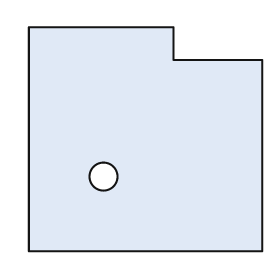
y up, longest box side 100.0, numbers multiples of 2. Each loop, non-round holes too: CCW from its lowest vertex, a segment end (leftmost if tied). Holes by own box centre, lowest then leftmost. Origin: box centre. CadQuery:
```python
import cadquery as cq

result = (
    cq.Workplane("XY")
    .moveTo(-50.0, -48.0)
    .lineTo(50.0, -48.0)
    .lineTo(50.0, 34.0)
    .lineTo(12.0, 34.0)
    .lineTo(12.0, 48.0)
    .lineTo(-50.0, 48.0)
    .close()
    .moveTo(-18.0, -16.0)
    .circle(6.0)
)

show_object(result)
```